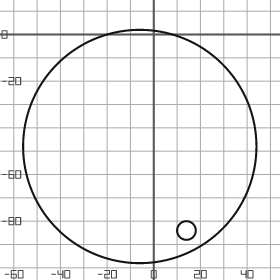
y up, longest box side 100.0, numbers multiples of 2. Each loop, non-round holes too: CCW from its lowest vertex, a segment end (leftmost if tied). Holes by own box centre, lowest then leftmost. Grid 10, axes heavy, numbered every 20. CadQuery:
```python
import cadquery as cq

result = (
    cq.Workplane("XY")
    .moveTo(-6.0, -48.0)
    .circle(50.0)
    .moveTo(14.0, -84.0)
    .circle(4.0)
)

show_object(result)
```